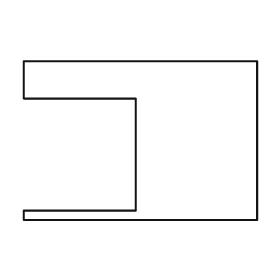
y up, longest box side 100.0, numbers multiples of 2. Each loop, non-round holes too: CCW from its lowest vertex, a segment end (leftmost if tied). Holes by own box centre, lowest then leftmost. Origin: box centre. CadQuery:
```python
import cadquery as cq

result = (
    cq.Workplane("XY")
    .moveTo(-50.0, -34.0)
    .lineTo(50.0, -34.0)
    .lineTo(50.0, 34.0)
    .lineTo(-50.0, 34.0)
    .lineTo(-50.0, 18.0)
    .lineTo(-2.0, 18.0)
    .lineTo(-2.0, -30.0)
    .lineTo(-50.0, -30.0)
    .close()
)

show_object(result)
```